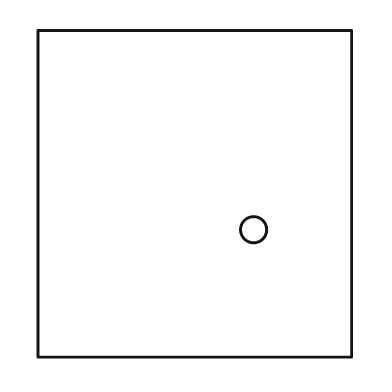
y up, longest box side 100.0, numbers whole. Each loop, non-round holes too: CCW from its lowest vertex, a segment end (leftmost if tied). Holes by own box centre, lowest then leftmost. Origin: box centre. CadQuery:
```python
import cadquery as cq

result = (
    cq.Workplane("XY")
    .moveTo(-48.0, -50.0)
    .lineTo(48.0, -50.0)
    .lineTo(48.0, 50.0)
    .lineTo(-48.0, 50.0)
    .close()
    .moveTo(18.0, -11.0)
    .circle(4.0)
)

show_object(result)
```